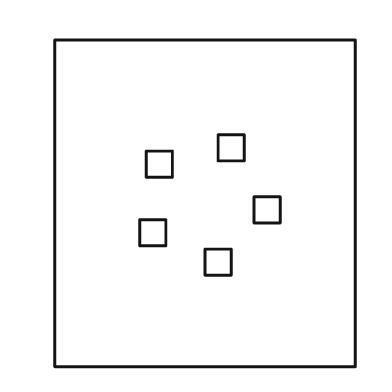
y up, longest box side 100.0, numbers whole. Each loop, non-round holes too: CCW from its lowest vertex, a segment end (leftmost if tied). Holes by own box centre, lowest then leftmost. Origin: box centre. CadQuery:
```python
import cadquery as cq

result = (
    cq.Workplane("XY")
    .moveTo(-46.0, -50.0)
    .lineTo(46.0, -50.0)
    .lineTo(46.0, 50.0)
    .lineTo(-46.0, 50.0)
    .close()
    .moveTo(0.0, -22.0)
    .lineTo(8.0, -22.0)
    .lineTo(8.0, -14.0)
    .lineTo(0.0, -14.0)
    .close()
    .moveTo(-20.0, -13.0)
    .lineTo(-12.0, -13.0)
    .lineTo(-12.0, -5.0)
    .lineTo(-20.0, -5.0)
    .close()
    .moveTo(15.0, -6.0)
    .lineTo(23.0, -6.0)
    .lineTo(23.0, 2.0)
    .lineTo(15.0, 2.0)
    .close()
    .moveTo(-18.0, 8.0)
    .lineTo(-10.0, 8.0)
    .lineTo(-10.0, 16.0)
    .lineTo(-18.0, 16.0)
    .close()
    .moveTo(4.0, 13.0)
    .lineTo(12.0, 13.0)
    .lineTo(12.0, 21.0)
    .lineTo(4.0, 21.0)
    .close()
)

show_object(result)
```